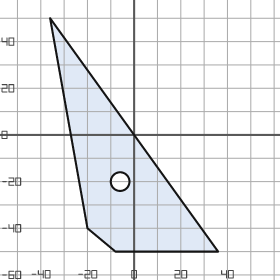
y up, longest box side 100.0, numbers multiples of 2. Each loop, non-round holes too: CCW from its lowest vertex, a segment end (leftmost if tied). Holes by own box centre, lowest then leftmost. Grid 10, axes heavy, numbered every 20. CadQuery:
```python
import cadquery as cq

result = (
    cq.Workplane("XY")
    .moveTo(-8.0, -50.0)
    .lineTo(36.0, -50.0)
    .lineTo(-36.0, 50.0)
    .lineTo(-20.0, -40.0)
    .close()
    .moveTo(-6.0, -20.0)
    .circle(4.0)
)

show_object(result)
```